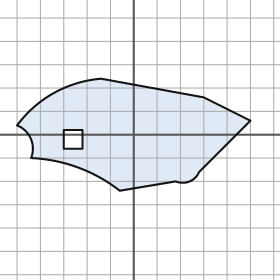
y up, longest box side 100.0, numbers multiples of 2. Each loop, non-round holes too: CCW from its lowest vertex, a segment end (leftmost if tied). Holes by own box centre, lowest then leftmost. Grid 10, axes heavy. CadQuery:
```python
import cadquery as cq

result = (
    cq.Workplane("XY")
    .moveTo(-6.0, -24.0)
    .lineTo(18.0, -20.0)
    .threePointArc((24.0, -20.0), (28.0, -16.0))
    .lineTo(50.0, 6.0)
    .lineTo(30.0, 16.0)
    .lineTo(-14.0, 24.0)
    .threePointArc((-34.0, 18.0), (-50.0, 4.0))
    .threePointArc((-44.0, -2.0), (-44.0, -10.0))
    .threePointArc((-24.0, -14.0), (-6.0, -24.0))
    .close()
    .moveTo(-30.0, -6.0)
    .lineTo(-22.0, -6.0)
    .lineTo(-22.0, 2.0)
    .lineTo(-30.0, 2.0)
    .close()
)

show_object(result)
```